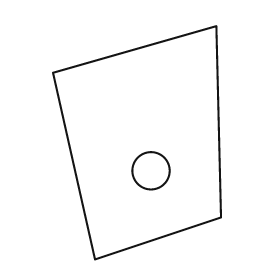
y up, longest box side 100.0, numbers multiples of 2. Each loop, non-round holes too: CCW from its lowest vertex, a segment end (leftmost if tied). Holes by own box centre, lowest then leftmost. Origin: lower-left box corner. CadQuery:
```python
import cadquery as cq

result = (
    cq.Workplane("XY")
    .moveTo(18.0, 0.0)
    .lineTo(72.0, 18.0)
    .lineTo(70.0, 100.0)
    .lineTo(0.0, 80.0)
    .close()
    .moveTo(42.0, 38.0)
    .circle(8.0)
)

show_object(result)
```